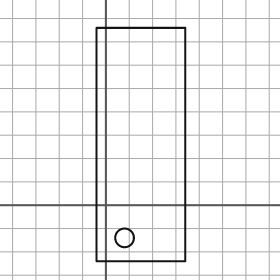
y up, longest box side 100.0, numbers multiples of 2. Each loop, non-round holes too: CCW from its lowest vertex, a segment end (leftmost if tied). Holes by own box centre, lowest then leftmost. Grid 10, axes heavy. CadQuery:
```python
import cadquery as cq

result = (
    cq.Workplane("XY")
    .moveTo(-4.0, -24.0)
    .lineTo(34.0, -24.0)
    .lineTo(34.0, 76.0)
    .lineTo(-4.0, 76.0)
    .close()
    .moveTo(8.0, -14.0)
    .circle(4.0)
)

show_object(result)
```